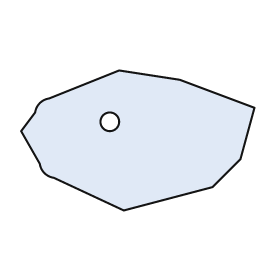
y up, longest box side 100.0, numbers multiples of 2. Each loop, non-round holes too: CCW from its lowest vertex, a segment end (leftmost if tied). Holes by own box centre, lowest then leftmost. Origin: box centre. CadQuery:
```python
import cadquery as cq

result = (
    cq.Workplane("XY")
    .moveTo(-6.0, -30.0)
    .lineTo(32.0, -20.0)
    .lineTo(44.0, -8.0)
    .lineTo(50.0, 14.0)
    .lineTo(18.0, 26.0)
    .lineTo(-8.0, 30.0)
    .lineTo(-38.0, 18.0)
    .threePointArc((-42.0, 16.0), (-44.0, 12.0))
    .lineTo(-50.0, 4.0)
    .lineTo(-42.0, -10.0)
    .threePointArc((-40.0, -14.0), (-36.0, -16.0))
    .close()
    .moveTo(-12.0, 8.0)
    .circle(4.0)
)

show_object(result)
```